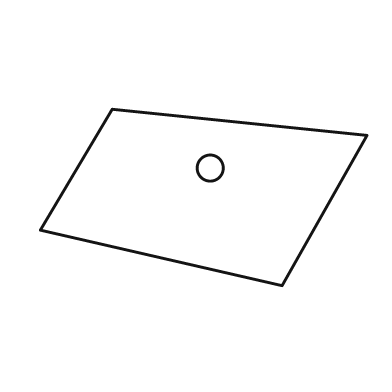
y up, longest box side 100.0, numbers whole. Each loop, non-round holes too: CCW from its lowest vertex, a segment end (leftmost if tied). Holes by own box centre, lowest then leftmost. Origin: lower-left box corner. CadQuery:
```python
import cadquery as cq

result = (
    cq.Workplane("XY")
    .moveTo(74.0, 0.0)
    .lineTo(100.0, 46.0)
    .lineTo(22.0, 54.0)
    .lineTo(0.0, 17.0)
    .close()
    .moveTo(52.0, 36.0)
    .circle(4.0)
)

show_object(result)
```